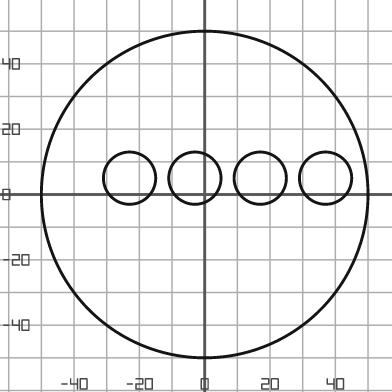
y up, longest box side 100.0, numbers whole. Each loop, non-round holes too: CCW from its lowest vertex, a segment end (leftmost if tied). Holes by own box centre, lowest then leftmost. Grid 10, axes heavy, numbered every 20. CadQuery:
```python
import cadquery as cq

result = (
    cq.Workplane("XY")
    .moveTo(0.0, 0.0)
    .circle(50.0)
    .moveTo(-23.0, 5.0)
    .circle(8.0)
    .moveTo(-3.0, 5.0)
    .circle(8.0)
    .moveTo(17.0, 5.0)
    .circle(8.0)
    .moveTo(37.0, 5.0)
    .circle(8.0)
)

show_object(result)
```